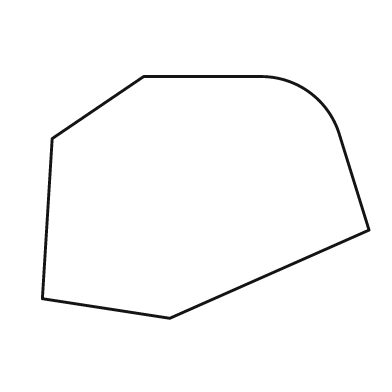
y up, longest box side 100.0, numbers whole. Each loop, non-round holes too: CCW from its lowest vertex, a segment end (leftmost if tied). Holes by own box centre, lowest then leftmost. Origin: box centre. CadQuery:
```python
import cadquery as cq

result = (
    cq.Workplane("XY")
    .moveTo(-11.0, -37.0)
    .lineTo(50.0, -10.0)
    .lineTo(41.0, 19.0)
    .threePointArc((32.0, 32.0), (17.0, 37.0))
    .lineTo(-19.0, 37.0)
    .lineTo(-47.0, 18.0)
    .lineTo(-50.0, -31.0)
    .close()
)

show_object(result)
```